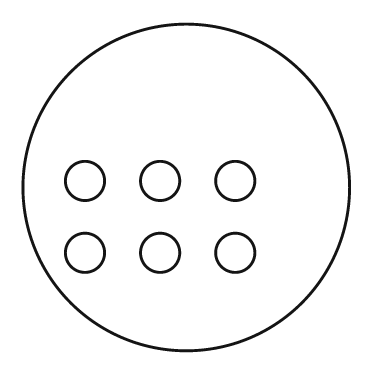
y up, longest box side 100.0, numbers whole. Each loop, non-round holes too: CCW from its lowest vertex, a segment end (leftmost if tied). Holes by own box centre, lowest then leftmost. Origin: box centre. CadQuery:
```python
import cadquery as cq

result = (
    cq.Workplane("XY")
    .moveTo(0.0, 0.0)
    .circle(50.0)
    .moveTo(-31.0, -20.0)
    .circle(6.0)
    .moveTo(-8.0, -20.0)
    .circle(6.0)
    .moveTo(15.0, -20.0)
    .circle(6.0)
    .moveTo(-31.0, 2.0)
    .circle(6.0)
    .moveTo(-8.0, 2.0)
    .circle(6.0)
    .moveTo(15.0, 2.0)
    .circle(6.0)
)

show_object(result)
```